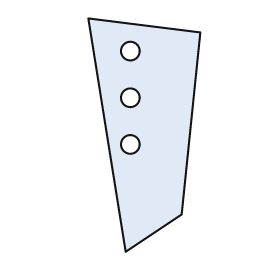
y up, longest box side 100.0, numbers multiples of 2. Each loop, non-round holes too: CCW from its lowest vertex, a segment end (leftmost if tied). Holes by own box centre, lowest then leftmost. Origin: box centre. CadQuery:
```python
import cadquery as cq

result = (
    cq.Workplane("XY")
    .moveTo(-8.0, -50.0)
    .lineTo(16.0, -34.0)
    .lineTo(24.0, 44.0)
    .lineTo(-24.0, 50.0)
    .close()
    .moveTo(-6.0, -4.0)
    .circle(4.0)
    .moveTo(-6.0, 16.0)
    .circle(4.0)
    .moveTo(-6.0, 36.0)
    .circle(4.0)
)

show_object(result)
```